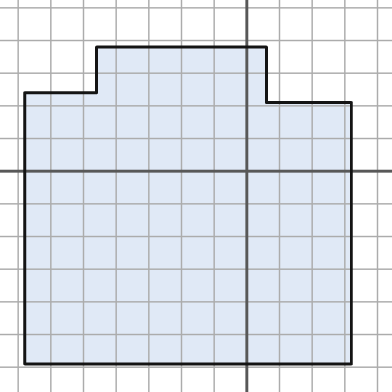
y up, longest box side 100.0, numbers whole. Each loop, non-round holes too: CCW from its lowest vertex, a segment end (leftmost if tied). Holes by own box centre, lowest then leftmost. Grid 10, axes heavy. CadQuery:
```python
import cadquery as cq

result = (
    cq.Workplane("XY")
    .moveTo(-68.0, -59.0)
    .lineTo(32.0, -59.0)
    .lineTo(32.0, 21.0)
    .lineTo(6.0, 21.0)
    .lineTo(6.0, 38.0)
    .lineTo(-46.0, 38.0)
    .lineTo(-46.0, 24.0)
    .lineTo(-68.0, 24.0)
    .close()
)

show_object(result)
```